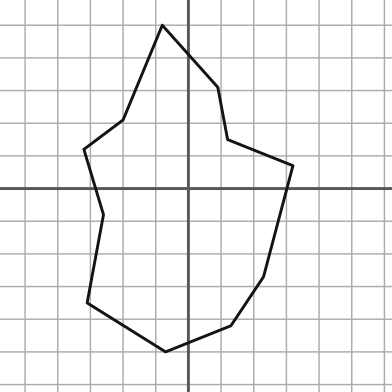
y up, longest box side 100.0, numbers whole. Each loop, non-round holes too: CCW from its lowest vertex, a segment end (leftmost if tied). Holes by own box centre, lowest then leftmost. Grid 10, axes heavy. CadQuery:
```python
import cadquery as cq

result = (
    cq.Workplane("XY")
    .moveTo(-7.0, -50.0)
    .lineTo(13.0, -42.0)
    .lineTo(23.0, -27.0)
    .lineTo(32.0, 7.0)
    .lineTo(12.0, 15.0)
    .lineTo(9.0, 31.0)
    .lineTo(-8.0, 50.0)
    .lineTo(-20.0, 21.0)
    .lineTo(-32.0, 12.0)
    .lineTo(-26.0, -8.0)
    .lineTo(-31.0, -35.0)
    .close()
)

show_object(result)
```